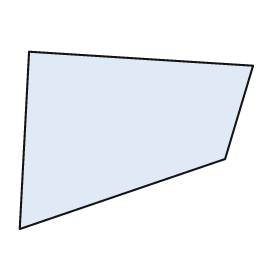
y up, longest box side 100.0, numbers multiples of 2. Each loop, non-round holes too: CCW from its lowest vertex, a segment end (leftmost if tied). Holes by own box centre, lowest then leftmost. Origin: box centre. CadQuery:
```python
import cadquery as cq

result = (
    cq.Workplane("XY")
    .moveTo(-50.0, -38.0)
    .lineTo(38.0, -8.0)
    .lineTo(50.0, 32.0)
    .lineTo(-46.0, 38.0)
    .close()
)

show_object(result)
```